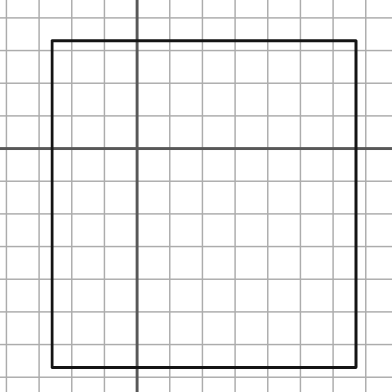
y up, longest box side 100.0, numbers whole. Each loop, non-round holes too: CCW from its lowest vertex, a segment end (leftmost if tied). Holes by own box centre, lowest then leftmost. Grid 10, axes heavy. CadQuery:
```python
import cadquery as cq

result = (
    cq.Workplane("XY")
    .moveTo(-26.0, -67.0)
    .lineTo(67.0, -67.0)
    .lineTo(67.0, 33.0)
    .lineTo(-26.0, 33.0)
    .close()
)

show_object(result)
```